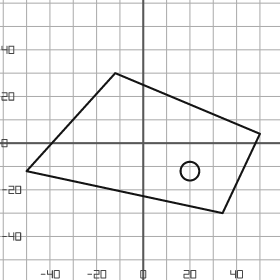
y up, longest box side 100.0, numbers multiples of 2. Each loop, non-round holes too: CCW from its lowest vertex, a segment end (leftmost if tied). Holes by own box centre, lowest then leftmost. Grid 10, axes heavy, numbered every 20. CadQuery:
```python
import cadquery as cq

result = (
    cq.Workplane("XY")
    .moveTo(34.0, -30.0)
    .lineTo(50.0, 4.0)
    .lineTo(-12.0, 30.0)
    .lineTo(-50.0, -12.0)
    .close()
    .moveTo(20.0, -12.0)
    .circle(4.0)
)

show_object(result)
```